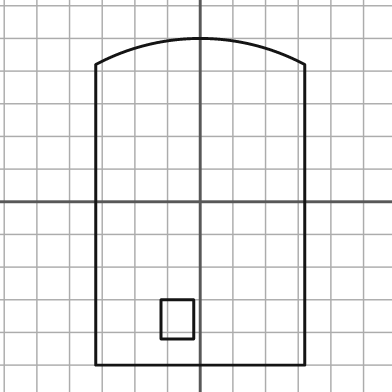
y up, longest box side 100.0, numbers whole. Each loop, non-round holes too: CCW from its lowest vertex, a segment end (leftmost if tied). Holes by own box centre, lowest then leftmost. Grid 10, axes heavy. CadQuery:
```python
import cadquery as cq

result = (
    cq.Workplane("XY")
    .moveTo(-32.0, -50.0)
    .lineTo(32.0, -50.0)
    .lineTo(32.0, 42.0)
    .threePointArc((0.0, 50.0), (-32.0, 42.0))
    .close()
    .moveTo(-12.0, -42.0)
    .lineTo(-2.0, -42.0)
    .lineTo(-2.0, -30.0)
    .lineTo(-12.0, -30.0)
    .close()
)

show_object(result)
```